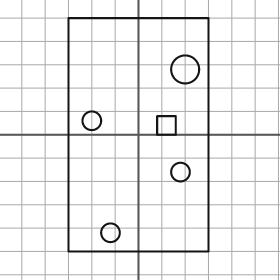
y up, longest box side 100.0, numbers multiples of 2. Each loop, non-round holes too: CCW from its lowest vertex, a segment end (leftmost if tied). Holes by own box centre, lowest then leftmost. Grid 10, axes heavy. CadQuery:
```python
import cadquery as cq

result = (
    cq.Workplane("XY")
    .moveTo(-30.0, -50.0)
    .lineTo(30.0, -50.0)
    .lineTo(30.0, 50.0)
    .lineTo(-30.0, 50.0)
    .close()
    .moveTo(-12.0, -42.0)
    .circle(4.0)
    .moveTo(18.0, -16.0)
    .circle(4.0)
    .moveTo(8.0, 0.0)
    .lineTo(16.0, 0.0)
    .lineTo(16.0, 8.0)
    .lineTo(8.0, 8.0)
    .close()
    .moveTo(-20.0, 6.0)
    .circle(4.0)
    .moveTo(20.0, 28.0)
    .circle(6.0)
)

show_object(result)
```